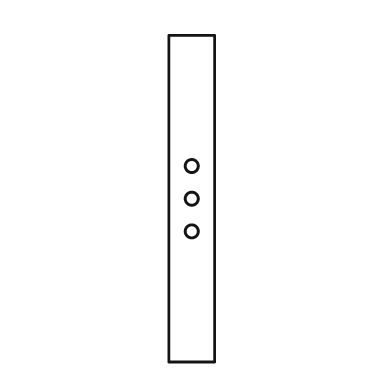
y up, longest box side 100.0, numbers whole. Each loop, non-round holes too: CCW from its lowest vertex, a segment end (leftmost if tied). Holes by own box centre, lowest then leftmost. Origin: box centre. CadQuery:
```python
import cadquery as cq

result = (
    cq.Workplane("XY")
    .moveTo(-7.0, -50.0)
    .lineTo(7.0, -50.0)
    .lineTo(7.0, 50.0)
    .lineTo(-7.0, 50.0)
    .close()
    .moveTo(0.0, -10.0)
    .circle(2.0)
    .moveTo(0.0, 0.0)
    .circle(2.0)
    .moveTo(0.0, 10.0)
    .circle(2.0)
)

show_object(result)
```